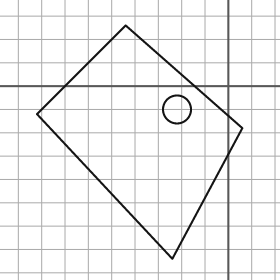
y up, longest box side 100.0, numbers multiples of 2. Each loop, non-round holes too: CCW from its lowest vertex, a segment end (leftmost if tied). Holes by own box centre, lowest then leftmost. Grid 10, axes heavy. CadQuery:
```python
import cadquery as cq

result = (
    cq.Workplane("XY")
    .moveTo(-24.0, -74.0)
    .lineTo(6.0, -18.0)
    .lineTo(-44.0, 26.0)
    .lineTo(-82.0, -12.0)
    .close()
    .moveTo(-22.0, -10.0)
    .circle(6.0)
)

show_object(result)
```